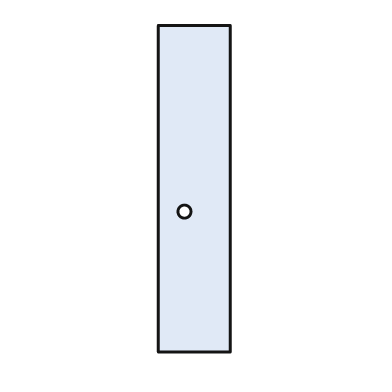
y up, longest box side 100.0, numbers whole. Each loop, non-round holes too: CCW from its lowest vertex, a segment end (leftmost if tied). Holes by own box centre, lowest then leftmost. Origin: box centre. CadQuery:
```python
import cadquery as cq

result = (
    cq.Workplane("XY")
    .moveTo(-11.0, -50.0)
    .lineTo(11.0, -50.0)
    .lineTo(11.0, 50.0)
    .lineTo(-11.0, 50.0)
    .close()
    .moveTo(-3.0, -7.0)
    .circle(2.0)
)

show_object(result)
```